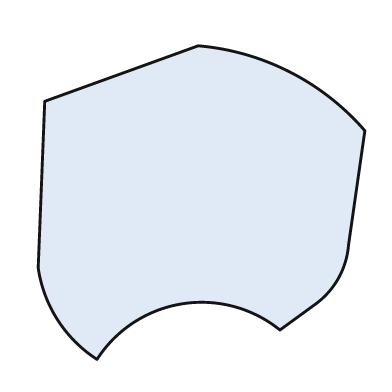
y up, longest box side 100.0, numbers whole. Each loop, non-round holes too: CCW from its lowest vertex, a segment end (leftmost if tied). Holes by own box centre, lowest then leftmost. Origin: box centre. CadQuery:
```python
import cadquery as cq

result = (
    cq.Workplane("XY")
    .moveTo(-32.0, -48.0)
    .threePointArc((-6.0, -31.0), (24.0, -39.0))
    .lineTo(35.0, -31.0)
    .threePointArc((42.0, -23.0), (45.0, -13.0))
    .lineTo(50.0, 22.0)
    .threePointArc((27.0, 40.0), (-1.0, 48.0))
    .lineTo(-48.0, 31.0)
    .lineTo(-50.0, -20.0)
    .threePointArc((-44.0, -36.0), (-32.0, -48.0))
    .close()
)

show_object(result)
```